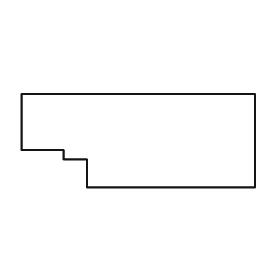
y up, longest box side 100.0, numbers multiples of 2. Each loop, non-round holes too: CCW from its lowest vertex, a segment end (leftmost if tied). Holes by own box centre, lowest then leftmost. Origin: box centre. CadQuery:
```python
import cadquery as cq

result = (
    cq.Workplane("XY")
    .moveTo(-22.0, -20.0)
    .lineTo(50.0, -20.0)
    .lineTo(50.0, 20.0)
    .lineTo(-50.0, 20.0)
    .lineTo(-50.0, -4.0)
    .lineTo(-32.0, -4.0)
    .lineTo(-32.0, -8.0)
    .lineTo(-22.0, -8.0)
    .close()
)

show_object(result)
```